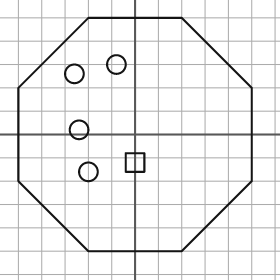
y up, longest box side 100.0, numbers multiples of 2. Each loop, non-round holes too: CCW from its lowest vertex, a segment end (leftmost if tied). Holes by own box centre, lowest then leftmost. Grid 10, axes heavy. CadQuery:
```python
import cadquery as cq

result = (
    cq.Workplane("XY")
    .moveTo(-20.0, -50.0)
    .lineTo(20.0, -50.0)
    .lineTo(50.0, -20.0)
    .lineTo(50.0, 20.0)
    .lineTo(20.0, 50.0)
    .lineTo(-20.0, 50.0)
    .lineTo(-50.0, 20.0)
    .lineTo(-50.0, -20.0)
    .close()
    .moveTo(-20.0, -16.0)
    .circle(4.0)
    .moveTo(-4.0, -16.0)
    .lineTo(4.0, -16.0)
    .lineTo(4.0, -8.0)
    .lineTo(-4.0, -8.0)
    .close()
    .moveTo(-24.0, 2.0)
    .circle(4.0)
    .moveTo(-26.0, 26.0)
    .circle(4.0)
    .moveTo(-8.0, 30.0)
    .circle(4.0)
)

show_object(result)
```